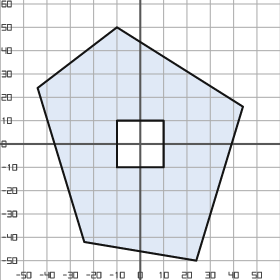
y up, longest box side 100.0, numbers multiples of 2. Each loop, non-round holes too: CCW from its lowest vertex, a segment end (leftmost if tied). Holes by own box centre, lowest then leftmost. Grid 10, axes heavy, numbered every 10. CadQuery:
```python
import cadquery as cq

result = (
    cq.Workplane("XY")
    .moveTo(24.0, -50.0)
    .lineTo(44.0, 16.0)
    .lineTo(-10.0, 50.0)
    .lineTo(-44.0, 24.0)
    .lineTo(-24.0, -42.0)
    .close()
    .moveTo(-10.0, -10.0)
    .lineTo(10.0, -10.0)
    .lineTo(10.0, 10.0)
    .lineTo(-10.0, 10.0)
    .close()
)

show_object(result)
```